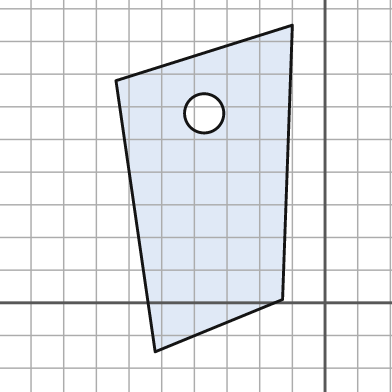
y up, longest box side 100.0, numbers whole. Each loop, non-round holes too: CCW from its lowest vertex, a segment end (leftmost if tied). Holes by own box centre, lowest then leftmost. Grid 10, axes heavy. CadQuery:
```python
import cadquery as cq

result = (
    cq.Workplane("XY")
    .moveTo(-52.0, -15.0)
    .lineTo(-13.0, 1.0)
    .lineTo(-10.0, 85.0)
    .lineTo(-64.0, 68.0)
    .close()
    .moveTo(-37.0, 58.0)
    .circle(6.0)
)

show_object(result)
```